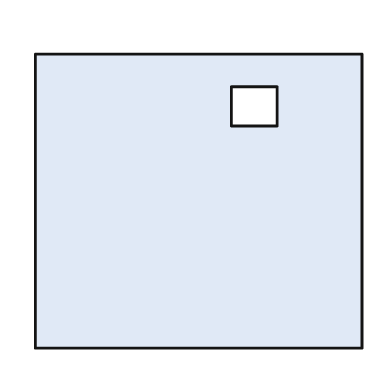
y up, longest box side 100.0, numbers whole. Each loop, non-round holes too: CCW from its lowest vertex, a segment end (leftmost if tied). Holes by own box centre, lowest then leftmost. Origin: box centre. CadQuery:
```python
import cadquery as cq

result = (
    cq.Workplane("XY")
    .moveTo(-50.0, -45.0)
    .lineTo(50.0, -45.0)
    .lineTo(50.0, 45.0)
    .lineTo(-50.0, 45.0)
    .close()
    .moveTo(10.0, 23.0)
    .lineTo(24.0, 23.0)
    .lineTo(24.0, 35.0)
    .lineTo(10.0, 35.0)
    .close()
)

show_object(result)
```